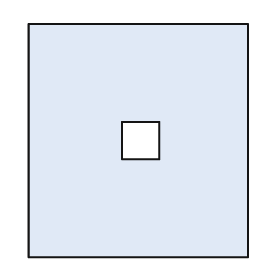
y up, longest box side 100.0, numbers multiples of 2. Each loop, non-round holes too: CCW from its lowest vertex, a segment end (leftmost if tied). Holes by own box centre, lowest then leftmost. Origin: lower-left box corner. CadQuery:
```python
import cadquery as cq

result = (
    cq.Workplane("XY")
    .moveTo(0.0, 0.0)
    .lineTo(94.0, 0.0)
    .lineTo(94.0, 100.0)
    .lineTo(0.0, 100.0)
    .close()
    .moveTo(40.0, 42.0)
    .lineTo(56.0, 42.0)
    .lineTo(56.0, 58.0)
    .lineTo(40.0, 58.0)
    .close()
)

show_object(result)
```